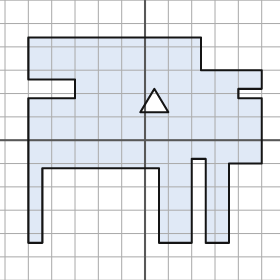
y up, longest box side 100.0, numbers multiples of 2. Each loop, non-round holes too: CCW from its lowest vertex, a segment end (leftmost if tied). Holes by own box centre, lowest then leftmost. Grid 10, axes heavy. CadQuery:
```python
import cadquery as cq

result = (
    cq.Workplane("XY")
    .moveTo(-50.0, -44.0)
    .lineTo(-44.0, -44.0)
    .lineTo(-44.0, -12.0)
    .lineTo(6.0, -12.0)
    .lineTo(6.0, -44.0)
    .lineTo(20.0, -44.0)
    .lineTo(20.0, -8.0)
    .lineTo(26.0, -8.0)
    .lineTo(26.0, -44.0)
    .lineTo(36.0, -44.0)
    .lineTo(36.0, -10.0)
    .lineTo(50.0, -10.0)
    .lineTo(50.0, 18.0)
    .lineTo(40.0, 18.0)
    .lineTo(40.0, 22.0)
    .lineTo(50.0, 22.0)
    .lineTo(50.0, 30.0)
    .lineTo(24.0, 30.0)
    .lineTo(24.0, 44.0)
    .lineTo(-50.0, 44.0)
    .lineTo(-50.0, 26.0)
    .lineTo(-30.0, 26.0)
    .lineTo(-30.0, 18.0)
    .lineTo(-50.0, 18.0)
    .close()
    .moveTo(-2.0, 12.0)
    .lineTo(10.0, 12.0)
    .lineTo(4.0, 22.0)
    .close()
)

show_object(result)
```